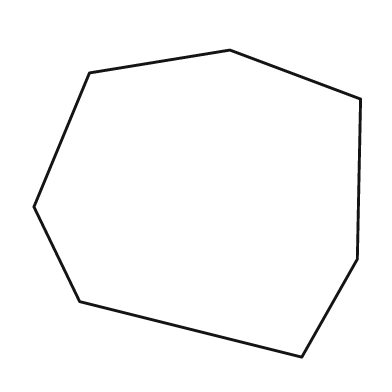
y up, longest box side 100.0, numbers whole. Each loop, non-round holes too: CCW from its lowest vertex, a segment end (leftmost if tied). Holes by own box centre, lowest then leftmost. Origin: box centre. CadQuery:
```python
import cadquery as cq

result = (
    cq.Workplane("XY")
    .moveTo(32.0, -47.0)
    .lineTo(49.0, -17.0)
    .lineTo(50.0, 32.0)
    .lineTo(10.0, 47.0)
    .lineTo(-33.0, 40.0)
    .lineTo(-50.0, -1.0)
    .lineTo(-36.0, -30.0)
    .close()
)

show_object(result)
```